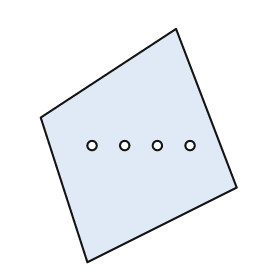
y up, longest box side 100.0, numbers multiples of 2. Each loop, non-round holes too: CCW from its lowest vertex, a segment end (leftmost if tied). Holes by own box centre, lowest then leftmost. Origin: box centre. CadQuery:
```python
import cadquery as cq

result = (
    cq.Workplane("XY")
    .moveTo(-22.0, -50.0)
    .lineTo(42.0, -18.0)
    .lineTo(16.0, 50.0)
    .lineTo(-42.0, 12.0)
    .close()
    .moveTo(-20.0, 0.0)
    .circle(2.0)
    .moveTo(-6.0, 0.0)
    .circle(2.0)
    .moveTo(8.0, 0.0)
    .circle(2.0)
    .moveTo(22.0, 0.0)
    .circle(2.0)
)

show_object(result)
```